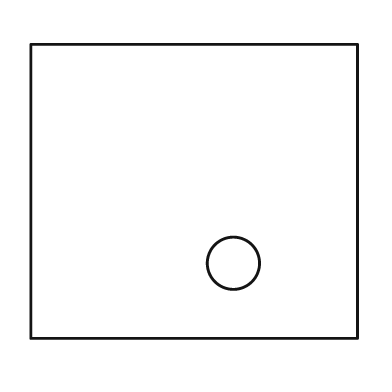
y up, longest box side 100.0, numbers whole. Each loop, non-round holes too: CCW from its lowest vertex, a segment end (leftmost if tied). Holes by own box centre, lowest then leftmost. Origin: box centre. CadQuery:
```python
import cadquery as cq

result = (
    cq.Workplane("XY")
    .moveTo(-50.0, -45.0)
    .lineTo(50.0, -45.0)
    .lineTo(50.0, 45.0)
    .lineTo(-50.0, 45.0)
    .close()
    .moveTo(12.0, -22.0)
    .circle(8.0)
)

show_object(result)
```